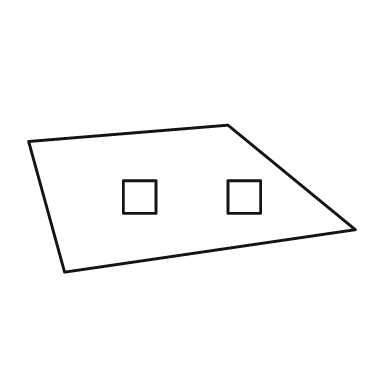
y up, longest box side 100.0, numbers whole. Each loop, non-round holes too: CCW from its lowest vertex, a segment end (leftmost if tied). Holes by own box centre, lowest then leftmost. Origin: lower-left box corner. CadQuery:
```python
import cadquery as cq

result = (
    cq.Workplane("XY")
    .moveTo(11.0, 0.0)
    .lineTo(100.0, 13.0)
    .lineTo(61.0, 45.0)
    .lineTo(0.0, 40.0)
    .close()
    .moveTo(29.0, 18.0)
    .lineTo(39.0, 18.0)
    .lineTo(39.0, 28.0)
    .lineTo(29.0, 28.0)
    .close()
    .moveTo(61.0, 18.0)
    .lineTo(71.0, 18.0)
    .lineTo(71.0, 28.0)
    .lineTo(61.0, 28.0)
    .close()
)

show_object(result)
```